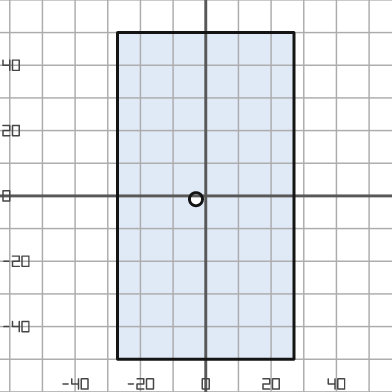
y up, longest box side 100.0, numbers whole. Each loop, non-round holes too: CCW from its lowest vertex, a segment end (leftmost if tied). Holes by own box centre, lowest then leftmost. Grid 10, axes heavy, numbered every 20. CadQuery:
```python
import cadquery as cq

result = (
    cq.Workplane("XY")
    .moveTo(-27.0, -50.0)
    .lineTo(27.0, -50.0)
    .lineTo(27.0, 50.0)
    .lineTo(-27.0, 50.0)
    .close()
    .moveTo(-3.0, -1.0)
    .circle(2.0)
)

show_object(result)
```